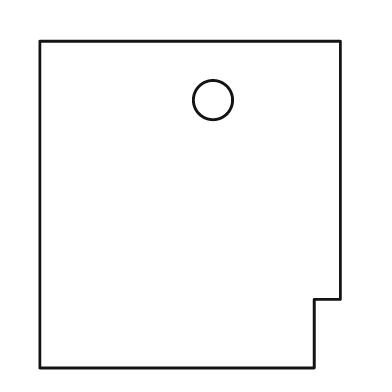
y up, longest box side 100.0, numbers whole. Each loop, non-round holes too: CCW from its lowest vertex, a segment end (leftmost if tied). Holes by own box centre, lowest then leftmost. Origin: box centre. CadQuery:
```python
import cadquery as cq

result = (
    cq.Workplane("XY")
    .moveTo(-46.0, -50.0)
    .lineTo(38.0, -50.0)
    .lineTo(38.0, -29.0)
    .lineTo(46.0, -29.0)
    .lineTo(46.0, 50.0)
    .lineTo(-46.0, 50.0)
    .close()
    .moveTo(7.0, 32.0)
    .circle(6.0)
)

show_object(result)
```